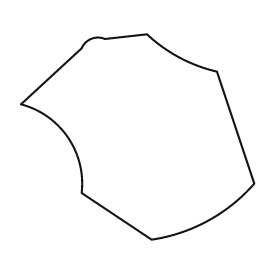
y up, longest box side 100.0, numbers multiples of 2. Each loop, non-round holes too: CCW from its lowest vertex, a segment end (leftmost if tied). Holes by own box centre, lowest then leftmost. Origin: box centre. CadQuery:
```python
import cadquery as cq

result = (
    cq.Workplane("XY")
    .moveTo(6.0, -44.0)
    .threePointArc((30.0, -36.0), (50.0, -20.0))
    .lineTo(34.0, 28.0)
    .threePointArc((18.0, 34.0), (4.0, 44.0))
    .lineTo(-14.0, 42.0)
    .threePointArc((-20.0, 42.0), (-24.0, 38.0))
    .lineTo(-50.0, 14.0)
    .threePointArc((-30.0, 0.0), (-24.0, -24.0))
    .close()
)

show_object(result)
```